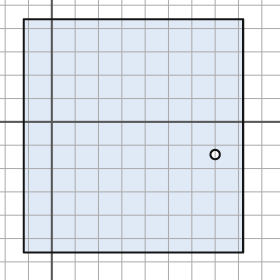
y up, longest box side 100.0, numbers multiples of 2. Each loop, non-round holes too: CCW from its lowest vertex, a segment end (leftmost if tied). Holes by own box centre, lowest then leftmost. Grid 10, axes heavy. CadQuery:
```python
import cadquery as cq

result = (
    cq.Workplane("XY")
    .moveTo(-12.0, -56.0)
    .lineTo(82.0, -56.0)
    .lineTo(82.0, 44.0)
    .lineTo(-12.0, 44.0)
    .close()
    .moveTo(70.0, -14.0)
    .circle(2.0)
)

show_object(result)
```